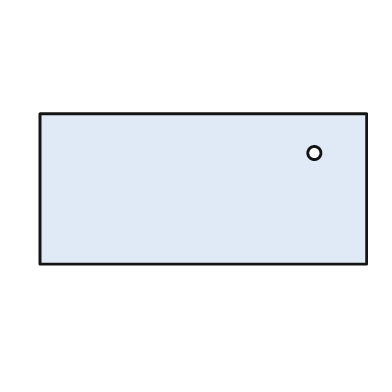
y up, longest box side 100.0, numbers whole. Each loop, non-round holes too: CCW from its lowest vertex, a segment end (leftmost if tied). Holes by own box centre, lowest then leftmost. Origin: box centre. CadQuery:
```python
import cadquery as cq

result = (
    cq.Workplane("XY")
    .moveTo(-50.0, -23.0)
    .lineTo(50.0, -23.0)
    .lineTo(50.0, 23.0)
    .lineTo(-50.0, 23.0)
    .close()
    .moveTo(34.0, 11.0)
    .circle(2.0)
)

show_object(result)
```